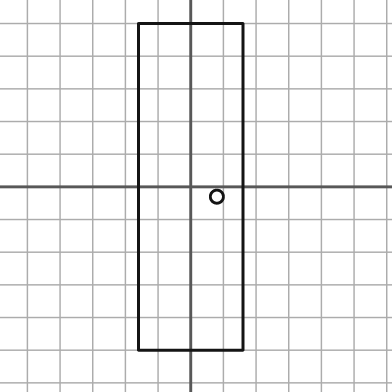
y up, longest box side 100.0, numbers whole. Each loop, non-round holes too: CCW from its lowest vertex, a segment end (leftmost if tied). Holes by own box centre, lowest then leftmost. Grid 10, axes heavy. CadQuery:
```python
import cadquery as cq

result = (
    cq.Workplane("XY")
    .moveTo(-16.0, -50.0)
    .lineTo(16.0, -50.0)
    .lineTo(16.0, 50.0)
    .lineTo(-16.0, 50.0)
    .close()
    .moveTo(8.0, -3.0)
    .circle(2.0)
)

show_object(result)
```